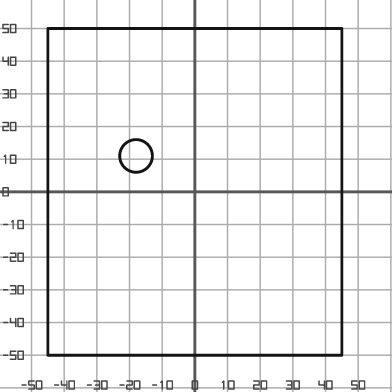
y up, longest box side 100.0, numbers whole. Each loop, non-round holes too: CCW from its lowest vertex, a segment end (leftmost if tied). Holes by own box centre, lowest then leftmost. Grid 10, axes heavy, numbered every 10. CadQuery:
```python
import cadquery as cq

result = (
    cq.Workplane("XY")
    .moveTo(-45.0, -50.0)
    .lineTo(45.0, -50.0)
    .lineTo(45.0, 50.0)
    .lineTo(-45.0, 50.0)
    .close()
    .moveTo(-18.0, 11.0)
    .circle(5.0)
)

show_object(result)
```